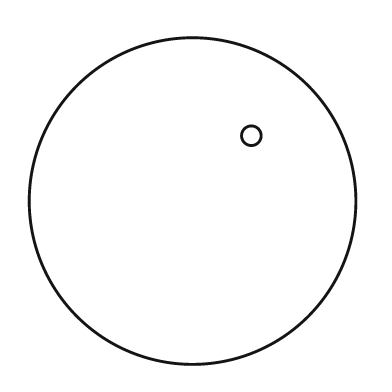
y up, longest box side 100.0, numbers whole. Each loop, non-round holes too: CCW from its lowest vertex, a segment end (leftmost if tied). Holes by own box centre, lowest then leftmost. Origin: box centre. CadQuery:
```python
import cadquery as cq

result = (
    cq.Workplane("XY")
    .moveTo(0.0, 0.0)
    .circle(50.0)
    .moveTo(18.0, 20.0)
    .circle(3.0)
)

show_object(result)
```